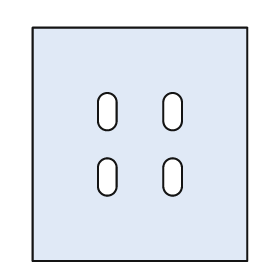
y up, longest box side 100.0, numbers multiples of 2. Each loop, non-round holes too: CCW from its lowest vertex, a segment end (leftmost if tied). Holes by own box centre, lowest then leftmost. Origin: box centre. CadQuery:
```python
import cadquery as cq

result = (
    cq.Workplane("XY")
    .moveTo(-46.0, -50.0)
    .lineTo(46.0, -50.0)
    .lineTo(46.0, 50.0)
    .lineTo(-46.0, 50.0)
    .close()
    .moveTo(-18.0, -18.0)
    .threePointArc((-14.0, -22.0), (-10.0, -18.0))
    .lineTo(-10.0, -10.0)
    .threePointArc((-14.0, -6.0), (-18.0, -10.0))
    .close()
    .moveTo(10.0, -18.0)
    .threePointArc((14.0, -22.0), (18.0, -18.0))
    .lineTo(18.0, -10.0)
    .threePointArc((14.0, -6.0), (10.0, -10.0))
    .close()
    .moveTo(-18.0, 10.0)
    .threePointArc((-14.0, 6.0), (-10.0, 10.0))
    .lineTo(-10.0, 18.0)
    .threePointArc((-14.0, 22.0), (-18.0, 18.0))
    .close()
    .moveTo(10.0, 10.0)
    .threePointArc((14.0, 6.0), (18.0, 10.0))
    .lineTo(18.0, 18.0)
    .threePointArc((14.0, 22.0), (10.0, 18.0))
    .close()
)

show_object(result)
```